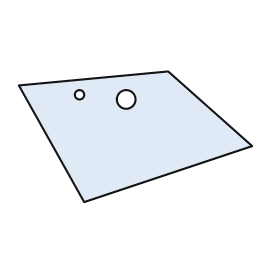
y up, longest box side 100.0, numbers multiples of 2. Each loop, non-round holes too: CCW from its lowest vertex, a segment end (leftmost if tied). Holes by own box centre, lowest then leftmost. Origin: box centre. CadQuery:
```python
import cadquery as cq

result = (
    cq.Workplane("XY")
    .moveTo(-22.0, -28.0)
    .lineTo(50.0, -4.0)
    .lineTo(14.0, 28.0)
    .lineTo(-50.0, 22.0)
    .close()
    .moveTo(-4.0, 16.0)
    .circle(4.0)
    .moveTo(-24.0, 18.0)
    .circle(2.0)
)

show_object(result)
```